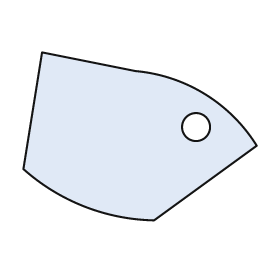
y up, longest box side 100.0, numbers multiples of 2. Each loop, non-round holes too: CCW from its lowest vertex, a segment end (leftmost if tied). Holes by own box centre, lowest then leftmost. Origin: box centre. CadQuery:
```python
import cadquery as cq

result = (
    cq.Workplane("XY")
    .moveTo(6.0, -36.0)
    .lineTo(50.0, -4.0)
    .threePointArc((28.0, 18.0), (-2.0, 28.0))
    .lineTo(-42.0, 36.0)
    .lineTo(-50.0, -14.0)
    .threePointArc((-24.0, -30.0), (6.0, -36.0))
    .close()
    .moveTo(24.0, 4.0)
    .circle(6.0)
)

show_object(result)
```